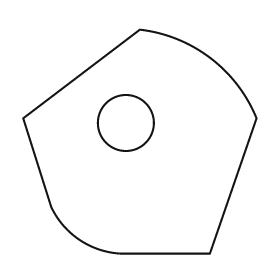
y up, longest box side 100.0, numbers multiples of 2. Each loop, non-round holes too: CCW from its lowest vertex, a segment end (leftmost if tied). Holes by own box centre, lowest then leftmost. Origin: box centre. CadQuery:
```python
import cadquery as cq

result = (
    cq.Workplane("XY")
    .moveTo(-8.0, -48.0)
    .lineTo(30.0, -48.0)
    .lineTo(50.0, 10.0)
    .threePointArc((30.0, 36.0), (0.0, 48.0))
    .lineTo(-50.0, 10.0)
    .lineTo(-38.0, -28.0)
    .threePointArc((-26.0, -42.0), (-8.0, -48.0))
    .close()
    .moveTo(-6.0, 8.0)
    .circle(12.0)
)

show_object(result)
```